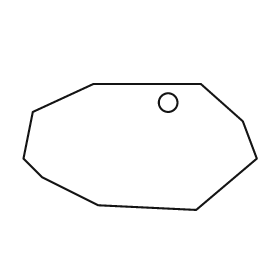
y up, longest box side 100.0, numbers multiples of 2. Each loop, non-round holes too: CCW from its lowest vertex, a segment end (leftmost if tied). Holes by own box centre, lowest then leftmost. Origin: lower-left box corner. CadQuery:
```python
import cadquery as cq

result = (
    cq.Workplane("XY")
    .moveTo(74.0, 0.0)
    .lineTo(100.0, 22.0)
    .lineTo(94.0, 38.0)
    .lineTo(76.0, 54.0)
    .lineTo(30.0, 54.0)
    .lineTo(4.0, 42.0)
    .lineTo(0.0, 22.0)
    .lineTo(8.0, 14.0)
    .lineTo(32.0, 2.0)
    .close()
    .moveTo(62.0, 46.0)
    .circle(4.0)
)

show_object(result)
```